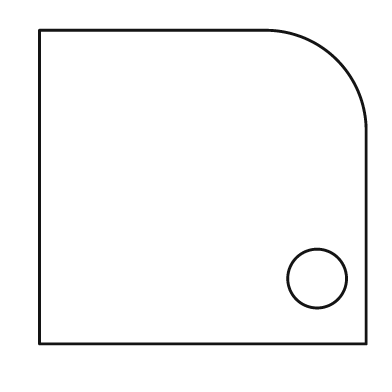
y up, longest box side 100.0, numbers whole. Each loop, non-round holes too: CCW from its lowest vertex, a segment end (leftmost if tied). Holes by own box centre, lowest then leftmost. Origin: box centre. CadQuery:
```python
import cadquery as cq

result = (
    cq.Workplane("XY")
    .moveTo(-50.0, -48.0)
    .lineTo(50.0, -48.0)
    .lineTo(50.0, 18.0)
    .threePointArc((41.0, 39.0), (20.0, 48.0))
    .lineTo(-50.0, 48.0)
    .close()
    .moveTo(35.0, -28.0)
    .circle(9.0)
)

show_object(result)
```